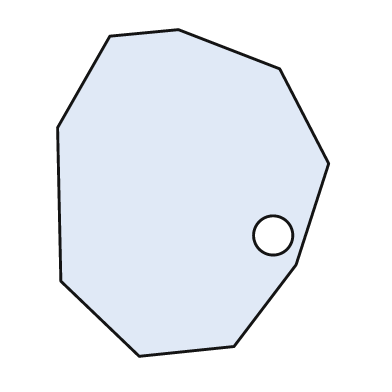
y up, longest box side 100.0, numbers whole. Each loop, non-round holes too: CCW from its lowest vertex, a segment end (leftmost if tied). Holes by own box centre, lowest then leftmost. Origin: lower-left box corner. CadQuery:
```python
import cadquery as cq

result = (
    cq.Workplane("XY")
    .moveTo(25.0, 0.0)
    .lineTo(54.0, 3.0)
    .lineTo(73.0, 28.0)
    .lineTo(83.0, 59.0)
    .lineTo(68.0, 88.0)
    .lineTo(37.0, 100.0)
    .lineTo(16.0, 98.0)
    .lineTo(0.0, 70.0)
    .lineTo(1.0, 23.0)
    .close()
    .moveTo(66.0, 37.0)
    .circle(6.0)
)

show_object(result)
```